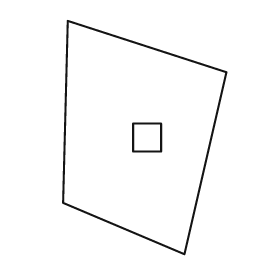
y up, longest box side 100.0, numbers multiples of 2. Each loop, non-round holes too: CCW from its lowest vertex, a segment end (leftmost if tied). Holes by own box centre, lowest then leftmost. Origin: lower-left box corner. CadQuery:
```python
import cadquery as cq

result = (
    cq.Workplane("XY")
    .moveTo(52.0, 0.0)
    .lineTo(70.0, 78.0)
    .lineTo(2.0, 100.0)
    .lineTo(0.0, 22.0)
    .close()
    .moveTo(30.0, 44.0)
    .lineTo(42.0, 44.0)
    .lineTo(42.0, 56.0)
    .lineTo(30.0, 56.0)
    .close()
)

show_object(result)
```